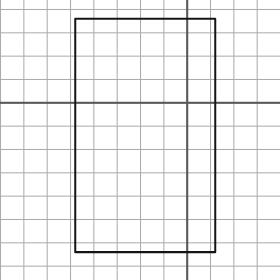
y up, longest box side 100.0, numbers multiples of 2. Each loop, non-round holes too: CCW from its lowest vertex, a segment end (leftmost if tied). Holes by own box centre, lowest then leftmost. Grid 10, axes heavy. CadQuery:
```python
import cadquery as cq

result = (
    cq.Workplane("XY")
    .moveTo(-48.0, -64.0)
    .lineTo(12.0, -64.0)
    .lineTo(12.0, 36.0)
    .lineTo(-48.0, 36.0)
    .close()
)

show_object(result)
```